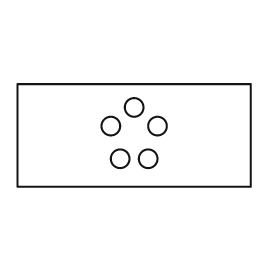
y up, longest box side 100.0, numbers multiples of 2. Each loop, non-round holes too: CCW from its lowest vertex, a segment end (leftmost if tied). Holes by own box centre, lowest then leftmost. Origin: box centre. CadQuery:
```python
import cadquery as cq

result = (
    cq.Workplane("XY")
    .moveTo(-50.0, -22.0)
    .lineTo(50.0, -22.0)
    .lineTo(50.0, 22.0)
    .lineTo(-50.0, 22.0)
    .close()
    .moveTo(-6.0, -10.0)
    .circle(4.0)
    .moveTo(6.0, -10.0)
    .circle(4.0)
    .moveTo(-10.0, 4.0)
    .circle(4.0)
    .moveTo(10.0, 4.0)
    .circle(4.0)
    .moveTo(0.0, 12.0)
    .circle(4.0)
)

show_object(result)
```